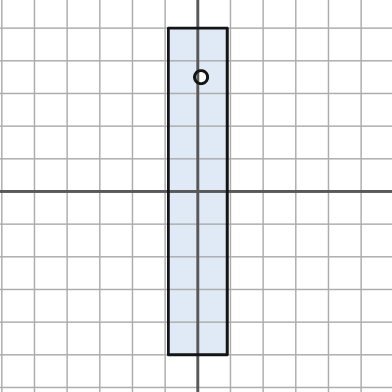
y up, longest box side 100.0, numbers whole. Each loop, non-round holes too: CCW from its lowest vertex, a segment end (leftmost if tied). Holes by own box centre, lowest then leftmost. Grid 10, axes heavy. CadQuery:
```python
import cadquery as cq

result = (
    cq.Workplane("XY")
    .moveTo(-9.0, -50.0)
    .lineTo(9.0, -50.0)
    .lineTo(9.0, 50.0)
    .lineTo(-9.0, 50.0)
    .close()
    .moveTo(1.0, 35.0)
    .circle(2.0)
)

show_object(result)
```